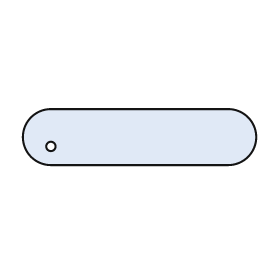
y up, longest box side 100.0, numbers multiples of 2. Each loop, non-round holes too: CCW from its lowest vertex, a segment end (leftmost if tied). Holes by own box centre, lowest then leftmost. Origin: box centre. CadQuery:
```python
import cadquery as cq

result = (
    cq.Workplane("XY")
    .moveTo(-38.0, -12.0)
    .lineTo(38.0, -12.0)
    .threePointArc((50.0, 0.0), (38.0, 12.0))
    .lineTo(-38.0, 12.0)
    .threePointArc((-50.0, 0.0), (-38.0, -12.0))
    .close()
    .moveTo(-38.0, -4.0)
    .circle(2.0)
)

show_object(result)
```